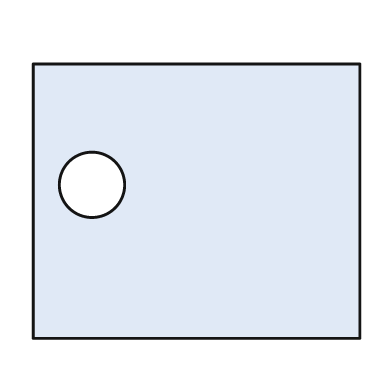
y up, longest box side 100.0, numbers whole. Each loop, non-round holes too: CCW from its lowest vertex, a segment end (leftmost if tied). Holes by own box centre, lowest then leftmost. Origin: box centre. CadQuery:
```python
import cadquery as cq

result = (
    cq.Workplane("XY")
    .moveTo(-50.0, -42.0)
    .lineTo(50.0, -42.0)
    .lineTo(50.0, 42.0)
    .lineTo(-50.0, 42.0)
    .close()
    .moveTo(-32.0, 5.0)
    .circle(10.0)
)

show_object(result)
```